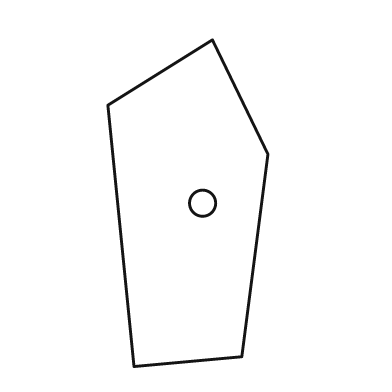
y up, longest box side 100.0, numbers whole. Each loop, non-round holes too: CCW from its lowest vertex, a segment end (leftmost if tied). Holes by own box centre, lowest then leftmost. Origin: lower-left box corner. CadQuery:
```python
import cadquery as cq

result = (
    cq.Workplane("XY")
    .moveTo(8.0, 0.0)
    .lineTo(41.0, 3.0)
    .lineTo(49.0, 65.0)
    .lineTo(32.0, 100.0)
    .lineTo(0.0, 80.0)
    .close()
    .moveTo(29.0, 50.0)
    .circle(4.0)
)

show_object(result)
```